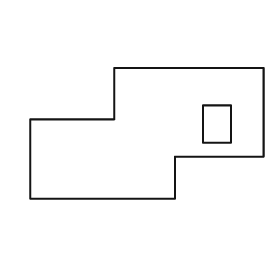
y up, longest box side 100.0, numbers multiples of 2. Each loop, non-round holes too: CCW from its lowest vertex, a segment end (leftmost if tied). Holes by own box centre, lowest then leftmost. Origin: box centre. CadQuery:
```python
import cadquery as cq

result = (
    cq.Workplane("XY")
    .moveTo(-50.0, -28.0)
    .lineTo(12.0, -28.0)
    .lineTo(12.0, -10.0)
    .lineTo(50.0, -10.0)
    .lineTo(50.0, 28.0)
    .lineTo(-14.0, 28.0)
    .lineTo(-14.0, 6.0)
    .lineTo(-50.0, 6.0)
    .close()
    .moveTo(24.0, -4.0)
    .lineTo(36.0, -4.0)
    .lineTo(36.0, 12.0)
    .lineTo(24.0, 12.0)
    .close()
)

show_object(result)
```